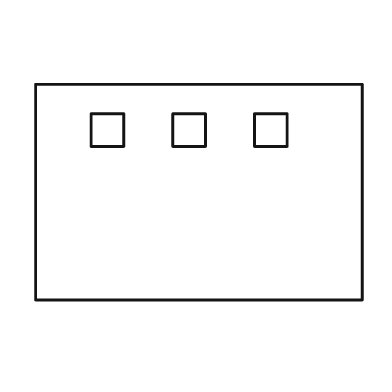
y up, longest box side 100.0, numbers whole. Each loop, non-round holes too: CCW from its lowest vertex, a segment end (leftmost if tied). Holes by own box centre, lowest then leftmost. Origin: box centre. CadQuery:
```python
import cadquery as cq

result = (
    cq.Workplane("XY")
    .moveTo(-50.0, -33.0)
    .lineTo(50.0, -33.0)
    .lineTo(50.0, 33.0)
    .lineTo(-50.0, 33.0)
    .close()
    .moveTo(-33.0, 14.0)
    .lineTo(-23.0, 14.0)
    .lineTo(-23.0, 24.0)
    .lineTo(-33.0, 24.0)
    .close()
    .moveTo(-8.0, 14.0)
    .lineTo(2.0, 14.0)
    .lineTo(2.0, 24.0)
    .lineTo(-8.0, 24.0)
    .close()
    .moveTo(17.0, 14.0)
    .lineTo(27.0, 14.0)
    .lineTo(27.0, 24.0)
    .lineTo(17.0, 24.0)
    .close()
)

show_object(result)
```